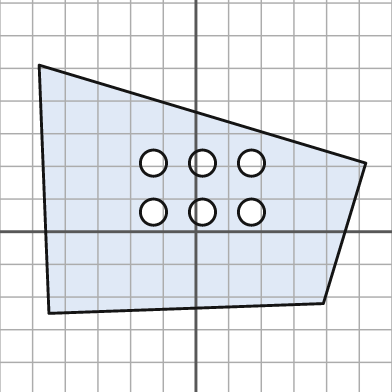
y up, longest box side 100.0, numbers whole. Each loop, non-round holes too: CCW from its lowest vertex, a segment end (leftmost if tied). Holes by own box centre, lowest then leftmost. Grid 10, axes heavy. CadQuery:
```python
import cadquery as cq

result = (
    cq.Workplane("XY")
    .moveTo(-45.0, -25.0)
    .lineTo(39.0, -22.0)
    .lineTo(52.0, 21.0)
    .lineTo(-48.0, 51.0)
    .close()
    .moveTo(-13.0, 6.0)
    .circle(4.0)
    .moveTo(2.0, 6.0)
    .circle(4.0)
    .moveTo(17.0, 6.0)
    .circle(4.0)
    .moveTo(-13.0, 21.0)
    .circle(4.0)
    .moveTo(2.0, 21.0)
    .circle(4.0)
    .moveTo(17.0, 21.0)
    .circle(4.0)
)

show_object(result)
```